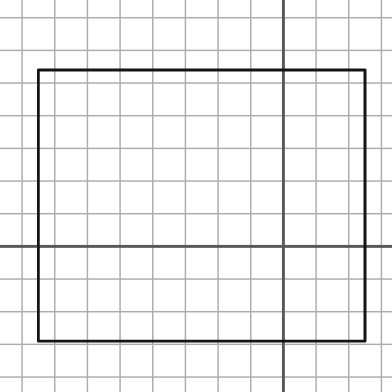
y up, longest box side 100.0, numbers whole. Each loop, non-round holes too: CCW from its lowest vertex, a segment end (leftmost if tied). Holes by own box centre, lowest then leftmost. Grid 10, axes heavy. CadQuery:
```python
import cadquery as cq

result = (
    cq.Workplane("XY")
    .moveTo(-75.0, -29.0)
    .lineTo(25.0, -29.0)
    .lineTo(25.0, 54.0)
    .lineTo(-75.0, 54.0)
    .close()
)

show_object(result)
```